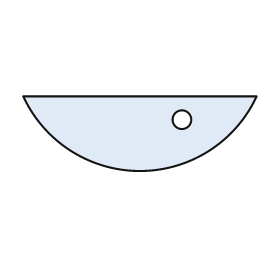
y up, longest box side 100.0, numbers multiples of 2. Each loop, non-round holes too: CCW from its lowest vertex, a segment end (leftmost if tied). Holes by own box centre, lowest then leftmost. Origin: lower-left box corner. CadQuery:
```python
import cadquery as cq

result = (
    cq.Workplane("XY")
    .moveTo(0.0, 32.0)
    .threePointArc((50.0, 0.0), (100.0, 32.0))
    .close()
    .moveTo(68.0, 22.0)
    .circle(4.0)
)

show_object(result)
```